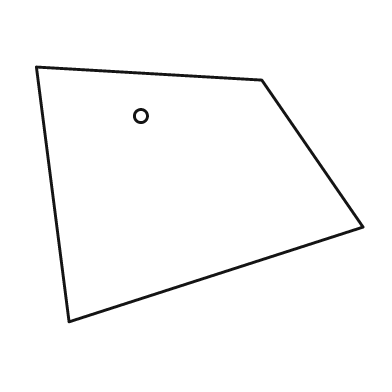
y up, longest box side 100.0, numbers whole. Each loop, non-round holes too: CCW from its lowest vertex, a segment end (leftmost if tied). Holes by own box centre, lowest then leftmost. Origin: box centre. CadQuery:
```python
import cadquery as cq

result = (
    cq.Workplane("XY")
    .moveTo(-40.0, -39.0)
    .lineTo(50.0, -10.0)
    .lineTo(19.0, 35.0)
    .lineTo(-50.0, 39.0)
    .close()
    .moveTo(-18.0, 24.0)
    .circle(2.0)
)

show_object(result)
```